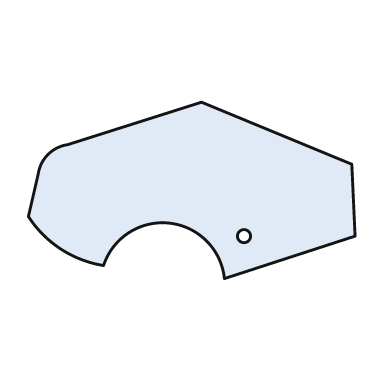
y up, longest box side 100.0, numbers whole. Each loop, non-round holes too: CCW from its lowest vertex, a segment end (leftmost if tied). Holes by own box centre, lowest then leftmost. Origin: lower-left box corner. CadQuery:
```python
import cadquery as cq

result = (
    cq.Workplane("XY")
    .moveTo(60.0, 0.0)
    .lineTo(100.0, 13.0)
    .lineTo(99.0, 35.0)
    .lineTo(53.0, 54.0)
    .lineTo(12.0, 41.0)
    .threePointArc((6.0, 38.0), (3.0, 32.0))
    .lineTo(0.0, 19.0)
    .threePointArc((10.0, 9.0), (23.0, 4.0))
    .threePointArc((43.0, 17.0), (60.0, 0.0))
    .close()
    .moveTo(66.0, 13.0)
    .circle(2.0)
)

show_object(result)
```